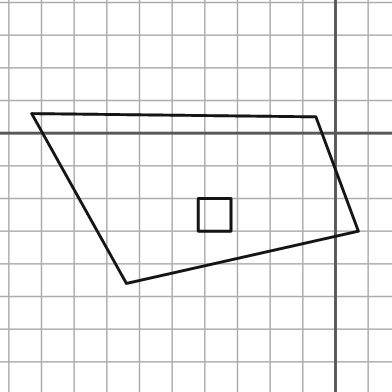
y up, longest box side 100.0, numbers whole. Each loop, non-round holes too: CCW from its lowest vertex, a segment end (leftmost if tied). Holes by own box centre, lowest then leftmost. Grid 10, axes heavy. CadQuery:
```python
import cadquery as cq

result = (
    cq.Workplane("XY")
    .moveTo(-64.0, -46.0)
    .lineTo(7.0, -30.0)
    .lineTo(-6.0, 5.0)
    .lineTo(-93.0, 6.0)
    .close()
    .moveTo(-42.0, -30.0)
    .lineTo(-32.0, -30.0)
    .lineTo(-32.0, -20.0)
    .lineTo(-42.0, -20.0)
    .close()
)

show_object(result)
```